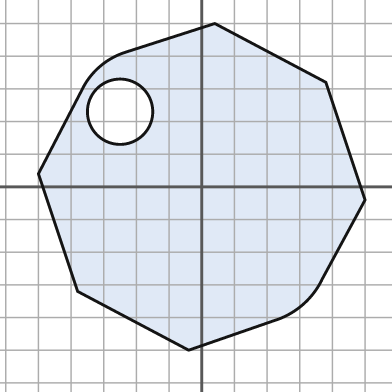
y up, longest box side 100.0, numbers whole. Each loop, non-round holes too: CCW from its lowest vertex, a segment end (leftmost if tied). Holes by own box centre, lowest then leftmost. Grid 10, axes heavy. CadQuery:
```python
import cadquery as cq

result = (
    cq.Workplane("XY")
    .moveTo(-4.0, -50.0)
    .lineTo(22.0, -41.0)
    .threePointArc((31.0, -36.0), (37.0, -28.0))
    .lineTo(50.0, -4.0)
    .lineTo(38.0, 32.0)
    .lineTo(4.0, 50.0)
    .lineTo(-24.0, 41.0)
    .threePointArc((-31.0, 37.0), (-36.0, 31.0))
    .lineTo(-50.0, 4.0)
    .lineTo(-38.0, -32.0)
    .close()
    .moveTo(-25.0, 23.0)
    .circle(10.0)
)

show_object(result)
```